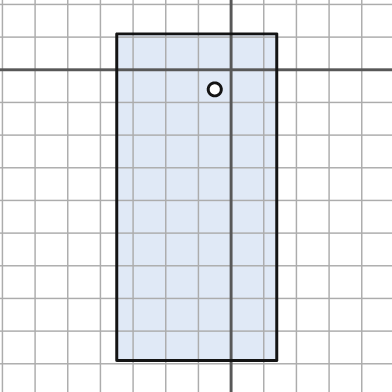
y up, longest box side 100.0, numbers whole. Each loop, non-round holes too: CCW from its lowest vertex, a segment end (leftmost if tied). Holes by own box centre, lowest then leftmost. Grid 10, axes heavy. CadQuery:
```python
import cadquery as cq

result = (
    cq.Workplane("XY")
    .moveTo(-35.0, -89.0)
    .lineTo(14.0, -89.0)
    .lineTo(14.0, 11.0)
    .lineTo(-35.0, 11.0)
    .close()
    .moveTo(-5.0, -6.0)
    .circle(2.0)
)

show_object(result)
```